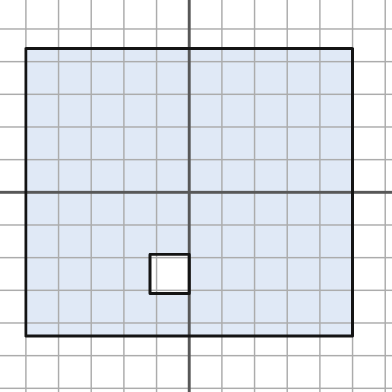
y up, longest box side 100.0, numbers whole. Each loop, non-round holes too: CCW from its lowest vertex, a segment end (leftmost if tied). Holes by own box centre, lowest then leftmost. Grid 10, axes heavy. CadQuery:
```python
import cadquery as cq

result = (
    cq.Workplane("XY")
    .moveTo(-50.0, -44.0)
    .lineTo(50.0, -44.0)
    .lineTo(50.0, 44.0)
    .lineTo(-50.0, 44.0)
    .close()
    .moveTo(-12.0, -31.0)
    .lineTo(0.0, -31.0)
    .lineTo(0.0, -19.0)
    .lineTo(-12.0, -19.0)
    .close()
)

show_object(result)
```